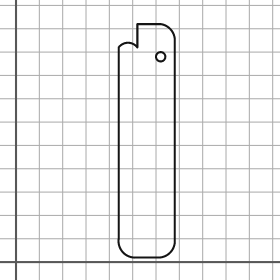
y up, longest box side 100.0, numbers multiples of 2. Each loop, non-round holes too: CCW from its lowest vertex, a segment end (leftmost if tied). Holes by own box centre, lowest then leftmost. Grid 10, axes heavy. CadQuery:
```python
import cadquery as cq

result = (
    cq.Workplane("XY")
    .moveTo(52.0, 2.0)
    .lineTo(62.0, 2.0)
    .threePointArc((66.0, 4.0), (68.0, 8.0))
    .lineTo(68.0, 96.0)
    .threePointArc((66.0, 100.0), (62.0, 102.0))
    .lineTo(52.0, 102.0)
    .lineTo(52.0, 92.0)
    .threePointArc((48.0, 94.0), (44.0, 92.0))
    .lineTo(44.0, 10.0)
    .threePointArc((46.0, 4.0), (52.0, 2.0))
    .close()
    .moveTo(62.0, 88.0)
    .circle(2.0)
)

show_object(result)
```